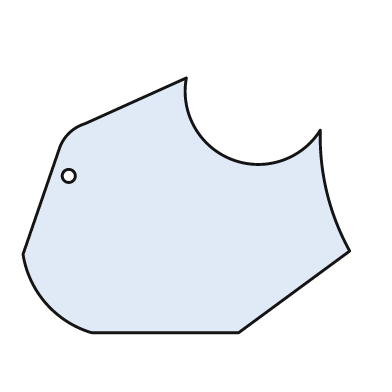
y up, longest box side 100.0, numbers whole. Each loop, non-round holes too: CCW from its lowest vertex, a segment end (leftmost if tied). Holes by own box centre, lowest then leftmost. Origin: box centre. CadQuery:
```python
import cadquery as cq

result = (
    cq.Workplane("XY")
    .moveTo(-29.0, -39.0)
    .lineTo(16.0, -39.0)
    .lineTo(50.0, -14.0)
    .threePointArc((43.0, 4.0), (41.0, 23.0))
    .threePointArc((14.0, 14.0), (0.0, 39.0))
    .lineTo(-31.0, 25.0)
    .threePointArc((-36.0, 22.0), (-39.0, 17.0))
    .lineTo(-50.0, -15.0)
    .threePointArc((-43.0, -30.0), (-29.0, -39.0))
    .close()
    .moveTo(-36.0, 9.0)
    .circle(2.0)
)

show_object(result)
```